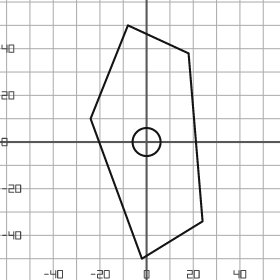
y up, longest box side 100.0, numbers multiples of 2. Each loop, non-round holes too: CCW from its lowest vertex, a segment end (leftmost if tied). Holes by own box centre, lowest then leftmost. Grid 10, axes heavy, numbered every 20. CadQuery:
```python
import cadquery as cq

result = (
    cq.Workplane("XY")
    .moveTo(-2.0, -50.0)
    .lineTo(24.0, -34.0)
    .lineTo(18.0, 38.0)
    .lineTo(-8.0, 50.0)
    .lineTo(-24.0, 10.0)
    .close()
    .moveTo(0.0, 0.0)
    .circle(6.0)
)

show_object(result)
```